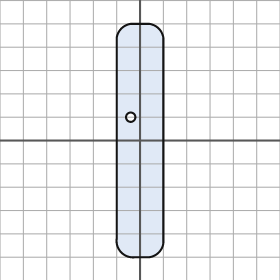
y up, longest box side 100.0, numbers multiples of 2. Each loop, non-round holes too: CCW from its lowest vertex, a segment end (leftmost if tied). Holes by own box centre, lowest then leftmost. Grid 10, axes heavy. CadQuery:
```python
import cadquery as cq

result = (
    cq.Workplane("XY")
    .moveTo(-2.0, -50.0)
    .lineTo(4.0, -50.0)
    .threePointArc((8.0, -48.0), (10.0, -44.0))
    .lineTo(10.0, 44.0)
    .threePointArc((8.0, 48.0), (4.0, 50.0))
    .lineTo(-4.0, 50.0)
    .threePointArc((-8.0, 48.0), (-10.0, 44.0))
    .lineTo(-10.0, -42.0)
    .threePointArc((-8.0, -48.0), (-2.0, -50.0))
    .close()
    .moveTo(-4.0, 10.0)
    .circle(2.0)
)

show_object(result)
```